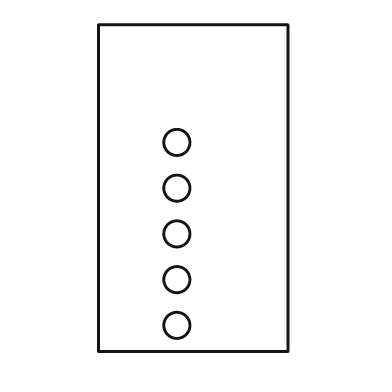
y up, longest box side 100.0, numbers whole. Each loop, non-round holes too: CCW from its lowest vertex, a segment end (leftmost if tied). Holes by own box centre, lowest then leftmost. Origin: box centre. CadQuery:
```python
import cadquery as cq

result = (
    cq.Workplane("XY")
    .moveTo(-29.0, -50.0)
    .lineTo(29.0, -50.0)
    .lineTo(29.0, 50.0)
    .lineTo(-29.0, 50.0)
    .close()
    .moveTo(-5.0, -42.0)
    .circle(4.0)
    .moveTo(-5.0, -28.0)
    .circle(4.0)
    .moveTo(-5.0, -14.0)
    .circle(4.0)
    .moveTo(-5.0, 0.0)
    .circle(4.0)
    .moveTo(-5.0, 14.0)
    .circle(4.0)
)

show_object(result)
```